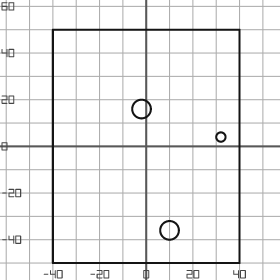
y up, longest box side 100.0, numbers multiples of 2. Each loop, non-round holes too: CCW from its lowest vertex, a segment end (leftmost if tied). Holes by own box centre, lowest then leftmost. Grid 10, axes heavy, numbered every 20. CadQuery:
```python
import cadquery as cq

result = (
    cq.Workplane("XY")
    .moveTo(-40.0, -50.0)
    .lineTo(40.0, -50.0)
    .lineTo(40.0, 50.0)
    .lineTo(-40.0, 50.0)
    .close()
    .moveTo(10.0, -36.0)
    .circle(4.0)
    .moveTo(32.0, 4.0)
    .circle(2.0)
    .moveTo(-2.0, 16.0)
    .circle(4.0)
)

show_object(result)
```